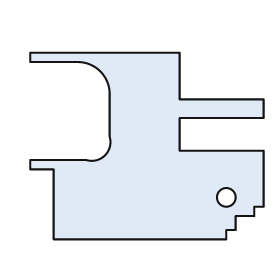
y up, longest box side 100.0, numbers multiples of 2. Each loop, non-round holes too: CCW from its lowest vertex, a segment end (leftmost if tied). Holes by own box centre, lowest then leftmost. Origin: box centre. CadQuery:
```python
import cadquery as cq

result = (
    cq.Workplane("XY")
    .moveTo(-40.0, -40.0)
    .lineTo(34.0, -40.0)
    .lineTo(34.0, -36.0)
    .lineTo(38.0, -36.0)
    .lineTo(38.0, -30.0)
    .lineTo(46.0, -30.0)
    .lineTo(46.0, -26.0)
    .lineTo(50.0, -26.0)
    .lineTo(50.0, -2.0)
    .lineTo(14.0, -2.0)
    .lineTo(14.0, 12.0)
    .lineTo(50.0, 12.0)
    .lineTo(50.0, 20.0)
    .lineTo(14.0, 20.0)
    .lineTo(14.0, 40.0)
    .lineTo(-50.0, 40.0)
    .lineTo(-50.0, 36.0)
    .lineTo(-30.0, 36.0)
    .threePointArc((-20.0, 32.0), (-16.0, 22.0))
    .lineTo(-16.0, 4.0)
    .threePointArc((-18.0, -4.0), (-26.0, -6.0))
    .lineTo(-50.0, -6.0)
    .lineTo(-50.0, -10.0)
    .lineTo(-40.0, -10.0)
    .close()
    .moveTo(34.0, -22.0)
    .circle(4.0)
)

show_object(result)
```